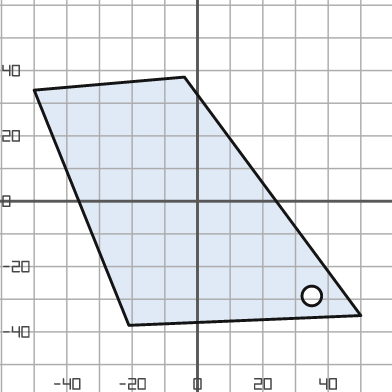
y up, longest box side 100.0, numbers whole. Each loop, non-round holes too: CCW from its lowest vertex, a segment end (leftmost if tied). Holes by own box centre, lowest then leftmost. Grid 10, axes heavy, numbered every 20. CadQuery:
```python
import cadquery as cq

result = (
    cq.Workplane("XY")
    .moveTo(-21.0, -38.0)
    .lineTo(50.0, -35.0)
    .lineTo(-4.0, 38.0)
    .lineTo(-50.0, 34.0)
    .close()
    .moveTo(35.0, -29.0)
    .circle(3.0)
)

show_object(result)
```